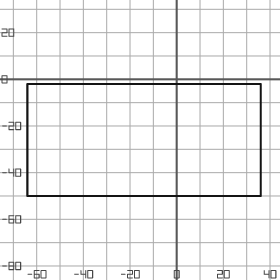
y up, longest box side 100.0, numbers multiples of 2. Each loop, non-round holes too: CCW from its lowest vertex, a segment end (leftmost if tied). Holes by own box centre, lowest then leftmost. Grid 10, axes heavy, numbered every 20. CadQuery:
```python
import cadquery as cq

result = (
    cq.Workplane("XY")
    .moveTo(-64.0, -50.0)
    .lineTo(36.0, -50.0)
    .lineTo(36.0, -2.0)
    .lineTo(-64.0, -2.0)
    .close()
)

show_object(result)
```